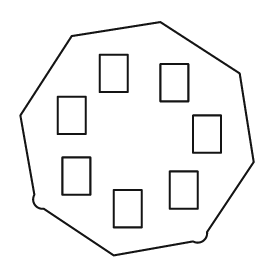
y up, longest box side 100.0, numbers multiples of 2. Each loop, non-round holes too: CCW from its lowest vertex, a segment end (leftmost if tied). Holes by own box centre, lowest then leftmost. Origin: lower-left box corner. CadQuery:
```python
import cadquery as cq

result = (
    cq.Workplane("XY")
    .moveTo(40.0, 0.0)
    .lineTo(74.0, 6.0)
    .threePointArc((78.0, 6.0), (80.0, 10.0))
    .lineTo(100.0, 40.0)
    .lineTo(94.0, 78.0)
    .lineTo(60.0, 100.0)
    .lineTo(22.0, 94.0)
    .lineTo(0.0, 60.0)
    .lineTo(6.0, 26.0)
    .threePointArc((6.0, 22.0), (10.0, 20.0))
    .close()
    .moveTo(40.0, 12.0)
    .lineTo(52.0, 12.0)
    .lineTo(52.0, 28.0)
    .lineTo(40.0, 28.0)
    .close()
    .moveTo(64.0, 20.0)
    .lineTo(76.0, 20.0)
    .lineTo(76.0, 36.0)
    .lineTo(64.0, 36.0)
    .close()
    .moveTo(18.0, 26.0)
    .lineTo(30.0, 26.0)
    .lineTo(30.0, 42.0)
    .lineTo(18.0, 42.0)
    .close()
    .moveTo(74.0, 44.0)
    .lineTo(86.0, 44.0)
    .lineTo(86.0, 60.0)
    .lineTo(74.0, 60.0)
    .close()
    .moveTo(16.0, 52.0)
    .lineTo(28.0, 52.0)
    .lineTo(28.0, 68.0)
    .lineTo(16.0, 68.0)
    .close()
    .moveTo(60.0, 66.0)
    .lineTo(72.0, 66.0)
    .lineTo(72.0, 82.0)
    .lineTo(60.0, 82.0)
    .close()
    .moveTo(34.0, 70.0)
    .lineTo(46.0, 70.0)
    .lineTo(46.0, 86.0)
    .lineTo(34.0, 86.0)
    .close()
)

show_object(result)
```